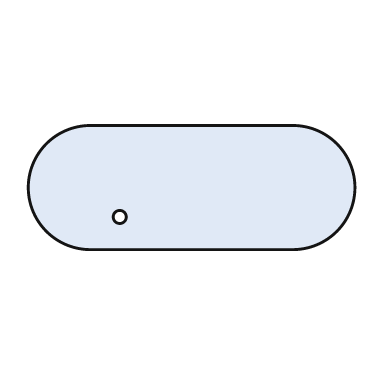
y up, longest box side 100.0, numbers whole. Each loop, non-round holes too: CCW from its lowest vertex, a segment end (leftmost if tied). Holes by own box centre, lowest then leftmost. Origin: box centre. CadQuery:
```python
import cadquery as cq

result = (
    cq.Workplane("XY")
    .moveTo(-31.0, -19.0)
    .lineTo(31.0, -19.0)
    .threePointArc((50.0, 0.0), (31.0, 19.0))
    .lineTo(-31.0, 19.0)
    .threePointArc((-50.0, 0.0), (-31.0, -19.0))
    .close()
    .moveTo(-22.0, -9.0)
    .circle(2.0)
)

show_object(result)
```